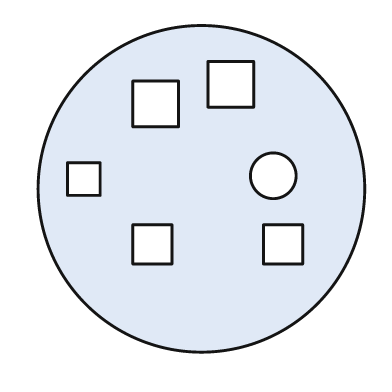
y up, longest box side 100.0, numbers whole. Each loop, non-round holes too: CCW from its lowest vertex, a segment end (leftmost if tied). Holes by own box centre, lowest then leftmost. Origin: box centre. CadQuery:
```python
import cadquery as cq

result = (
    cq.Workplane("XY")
    .moveTo(0.0, 0.0)
    .circle(50.0)
    .moveTo(-21.0, -23.0)
    .lineTo(-9.0, -23.0)
    .lineTo(-9.0, -11.0)
    .lineTo(-21.0, -11.0)
    .close()
    .moveTo(19.0, -23.0)
    .lineTo(31.0, -23.0)
    .lineTo(31.0, -11.0)
    .lineTo(19.0, -11.0)
    .close()
    .moveTo(-41.0, -2.0)
    .lineTo(-31.0, -2.0)
    .lineTo(-31.0, 8.0)
    .lineTo(-41.0, 8.0)
    .close()
    .moveTo(22.0, 4.0)
    .circle(7.0)
    .moveTo(-21.0, 19.0)
    .lineTo(-7.0, 19.0)
    .lineTo(-7.0, 33.0)
    .lineTo(-21.0, 33.0)
    .close()
    .moveTo(2.0, 25.0)
    .lineTo(16.0, 25.0)
    .lineTo(16.0, 39.0)
    .lineTo(2.0, 39.0)
    .close()
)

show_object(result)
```